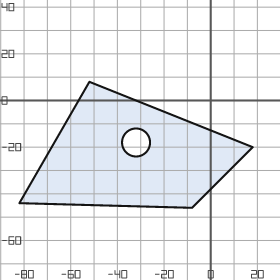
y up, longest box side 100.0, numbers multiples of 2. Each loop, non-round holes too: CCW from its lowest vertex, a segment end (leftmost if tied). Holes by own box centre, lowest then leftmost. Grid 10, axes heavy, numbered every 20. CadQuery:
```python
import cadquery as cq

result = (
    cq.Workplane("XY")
    .moveTo(-8.0, -46.0)
    .lineTo(18.0, -20.0)
    .lineTo(-52.0, 8.0)
    .lineTo(-82.0, -44.0)
    .close()
    .moveTo(-32.0, -18.0)
    .circle(6.0)
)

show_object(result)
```